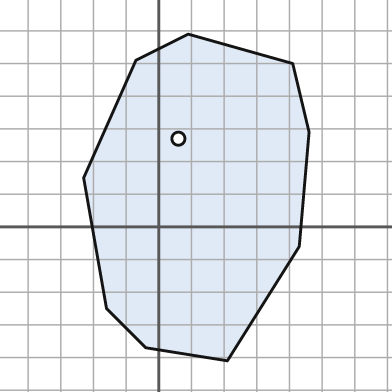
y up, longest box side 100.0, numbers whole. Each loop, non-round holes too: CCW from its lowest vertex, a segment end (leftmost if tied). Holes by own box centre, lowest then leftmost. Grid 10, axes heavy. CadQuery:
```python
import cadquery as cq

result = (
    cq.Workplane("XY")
    .moveTo(21.0, -41.0)
    .lineTo(43.0, -6.0)
    .lineTo(46.0, 29.0)
    .lineTo(41.0, 50.0)
    .lineTo(9.0, 59.0)
    .lineTo(-7.0, 51.0)
    .lineTo(-23.0, 15.0)
    .lineTo(-16.0, -25.0)
    .lineTo(-4.0, -37.0)
    .close()
    .moveTo(6.0, 27.0)
    .circle(2.0)
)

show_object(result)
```